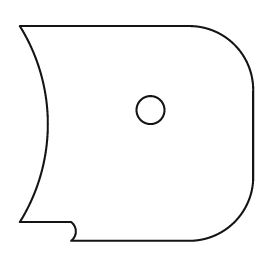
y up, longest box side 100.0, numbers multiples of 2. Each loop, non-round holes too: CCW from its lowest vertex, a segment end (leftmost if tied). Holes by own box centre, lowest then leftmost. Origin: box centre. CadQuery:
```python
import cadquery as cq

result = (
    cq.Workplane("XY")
    .moveTo(-28.0, -46.0)
    .lineTo(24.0, -46.0)
    .threePointArc((42.0, -38.0), (50.0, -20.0))
    .lineTo(50.0, 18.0)
    .threePointArc((42.0, 38.0), (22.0, 46.0))
    .lineTo(-50.0, 46.0)
    .threePointArc((-38.0, 4.0), (-50.0, -38.0))
    .lineTo(-28.0, -38.0)
    .threePointArc((-26.0, -42.0), (-28.0, -46.0))
    .close()
    .moveTo(6.0, 10.0)
    .circle(6.0)
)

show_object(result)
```